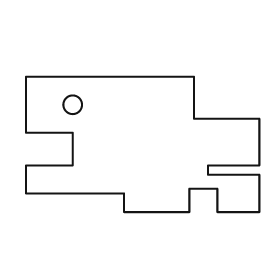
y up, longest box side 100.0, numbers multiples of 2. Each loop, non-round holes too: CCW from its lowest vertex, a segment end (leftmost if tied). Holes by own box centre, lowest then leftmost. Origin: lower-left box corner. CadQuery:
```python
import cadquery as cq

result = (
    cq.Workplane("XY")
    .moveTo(42.0, 0.0)
    .lineTo(70.0, 0.0)
    .lineTo(70.0, 10.0)
    .lineTo(82.0, 10.0)
    .lineTo(82.0, 0.0)
    .lineTo(100.0, 0.0)
    .lineTo(100.0, 16.0)
    .lineTo(78.0, 16.0)
    .lineTo(78.0, 20.0)
    .lineTo(100.0, 20.0)
    .lineTo(100.0, 40.0)
    .lineTo(72.0, 40.0)
    .lineTo(72.0, 58.0)
    .lineTo(0.0, 58.0)
    .lineTo(0.0, 34.0)
    .lineTo(20.0, 34.0)
    .lineTo(20.0, 20.0)
    .lineTo(0.0, 20.0)
    .lineTo(0.0, 8.0)
    .lineTo(42.0, 8.0)
    .close()
    .moveTo(20.0, 46.0)
    .circle(4.0)
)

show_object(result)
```